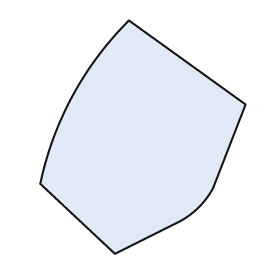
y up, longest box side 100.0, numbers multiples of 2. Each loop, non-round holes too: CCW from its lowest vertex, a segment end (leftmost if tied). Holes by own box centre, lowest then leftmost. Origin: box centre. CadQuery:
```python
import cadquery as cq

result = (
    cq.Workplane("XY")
    .moveTo(-12.0, -50.0)
    .lineTo(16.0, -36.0)
    .threePointArc((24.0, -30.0), (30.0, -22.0))
    .lineTo(44.0, 14.0)
    .lineTo(-6.0, 50.0)
    .threePointArc((-30.0, 18.0), (-44.0, -20.0))
    .close()
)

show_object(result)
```